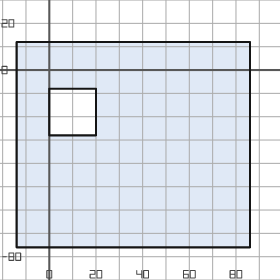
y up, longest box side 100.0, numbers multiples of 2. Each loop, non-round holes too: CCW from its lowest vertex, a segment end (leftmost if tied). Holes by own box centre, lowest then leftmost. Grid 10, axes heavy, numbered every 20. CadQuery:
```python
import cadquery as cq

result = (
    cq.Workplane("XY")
    .moveTo(-14.0, -76.0)
    .lineTo(86.0, -76.0)
    .lineTo(86.0, 12.0)
    .lineTo(-14.0, 12.0)
    .close()
    .moveTo(0.0, -28.0)
    .lineTo(20.0, -28.0)
    .lineTo(20.0, -8.0)
    .lineTo(0.0, -8.0)
    .close()
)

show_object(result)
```